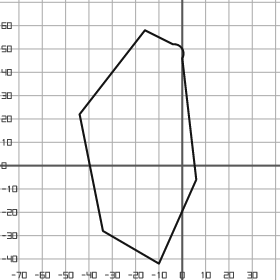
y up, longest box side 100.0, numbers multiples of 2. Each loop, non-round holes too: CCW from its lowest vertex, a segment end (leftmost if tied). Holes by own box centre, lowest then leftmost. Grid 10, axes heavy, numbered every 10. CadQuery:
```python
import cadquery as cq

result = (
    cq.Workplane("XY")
    .moveTo(-10.0, -42.0)
    .lineTo(6.0, -6.0)
    .lineTo(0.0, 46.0)
    .threePointArc((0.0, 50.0), (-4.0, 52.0))
    .lineTo(-16.0, 58.0)
    .lineTo(-44.0, 22.0)
    .lineTo(-34.0, -28.0)
    .close()
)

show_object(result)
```